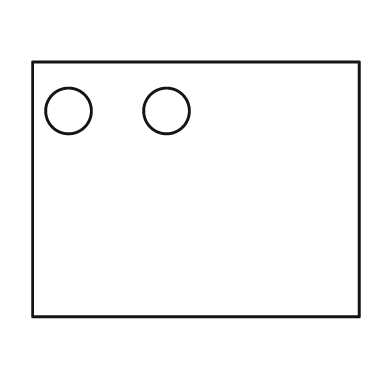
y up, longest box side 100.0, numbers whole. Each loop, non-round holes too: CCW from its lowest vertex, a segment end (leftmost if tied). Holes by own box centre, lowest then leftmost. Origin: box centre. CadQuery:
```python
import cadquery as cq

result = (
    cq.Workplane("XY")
    .moveTo(-50.0, -39.0)
    .lineTo(50.0, -39.0)
    .lineTo(50.0, 39.0)
    .lineTo(-50.0, 39.0)
    .close()
    .moveTo(-39.0, 24.0)
    .circle(7.0)
    .moveTo(-9.0, 24.0)
    .circle(7.0)
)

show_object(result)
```